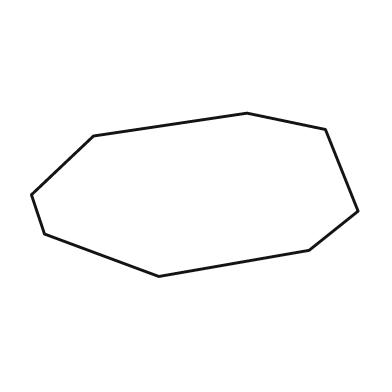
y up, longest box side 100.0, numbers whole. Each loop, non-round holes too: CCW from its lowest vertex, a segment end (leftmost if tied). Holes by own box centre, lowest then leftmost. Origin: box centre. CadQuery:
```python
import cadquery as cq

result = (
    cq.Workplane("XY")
    .moveTo(-11.0, -25.0)
    .lineTo(35.0, -17.0)
    .lineTo(50.0, -5.0)
    .lineTo(40.0, 20.0)
    .lineTo(16.0, 25.0)
    .lineTo(-31.0, 18.0)
    .lineTo(-50.0, 0.0)
    .lineTo(-46.0, -12.0)
    .close()
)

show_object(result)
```